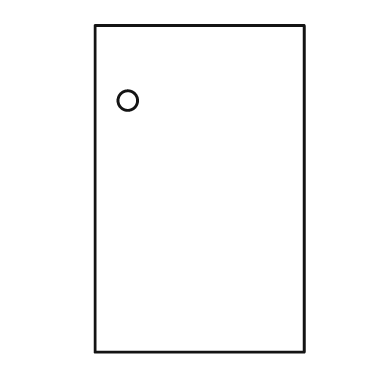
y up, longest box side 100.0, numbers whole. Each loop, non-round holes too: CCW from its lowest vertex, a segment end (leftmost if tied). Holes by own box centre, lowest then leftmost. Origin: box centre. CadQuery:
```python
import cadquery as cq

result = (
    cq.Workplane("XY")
    .moveTo(-32.0, -50.0)
    .lineTo(32.0, -50.0)
    .lineTo(32.0, 50.0)
    .lineTo(-32.0, 50.0)
    .close()
    .moveTo(-22.0, 27.0)
    .circle(3.0)
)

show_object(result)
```